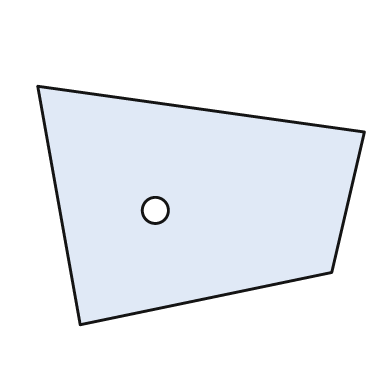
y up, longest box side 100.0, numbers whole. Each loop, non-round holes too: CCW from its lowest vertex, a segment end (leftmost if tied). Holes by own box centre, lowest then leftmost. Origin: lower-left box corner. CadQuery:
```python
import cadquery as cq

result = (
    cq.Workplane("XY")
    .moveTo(13.0, 0.0)
    .lineTo(90.0, 16.0)
    .lineTo(100.0, 59.0)
    .lineTo(0.0, 73.0)
    .close()
    .moveTo(36.0, 35.0)
    .circle(4.0)
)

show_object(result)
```